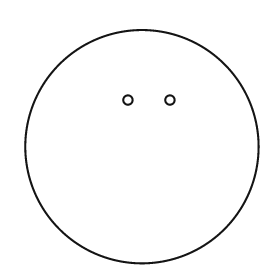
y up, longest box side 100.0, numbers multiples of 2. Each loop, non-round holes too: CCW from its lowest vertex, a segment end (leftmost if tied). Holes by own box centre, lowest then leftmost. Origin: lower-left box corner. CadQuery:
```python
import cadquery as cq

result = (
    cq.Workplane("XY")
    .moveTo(50.0, 50.0)
    .circle(50.0)
    .moveTo(44.0, 70.0)
    .circle(2.0)
    .moveTo(62.0, 70.0)
    .circle(2.0)
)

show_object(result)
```